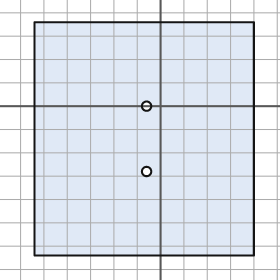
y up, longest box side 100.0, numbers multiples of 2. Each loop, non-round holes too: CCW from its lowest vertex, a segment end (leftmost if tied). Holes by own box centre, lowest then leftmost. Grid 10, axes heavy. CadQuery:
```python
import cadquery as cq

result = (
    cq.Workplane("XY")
    .moveTo(-54.0, -64.0)
    .lineTo(40.0, -64.0)
    .lineTo(40.0, 36.0)
    .lineTo(-54.0, 36.0)
    .close()
    .moveTo(-6.0, -28.0)
    .circle(2.0)
    .moveTo(-6.0, 0.0)
    .circle(2.0)
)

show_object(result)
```